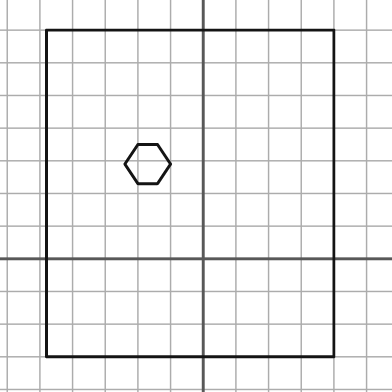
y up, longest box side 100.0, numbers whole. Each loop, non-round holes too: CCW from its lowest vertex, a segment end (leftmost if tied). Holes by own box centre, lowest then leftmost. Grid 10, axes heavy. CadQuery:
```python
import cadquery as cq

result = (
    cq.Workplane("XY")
    .moveTo(-48.0, -30.0)
    .lineTo(40.0, -30.0)
    .lineTo(40.0, 70.0)
    .lineTo(-48.0, 70.0)
    .close()
    .moveTo(-20.0, 23.0)
    .lineTo(-14.0, 23.0)
    .lineTo(-10.0, 29.0)
    .lineTo(-14.0, 35.0)
    .lineTo(-20.0, 35.0)
    .lineTo(-24.0, 29.0)
    .close()
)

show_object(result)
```